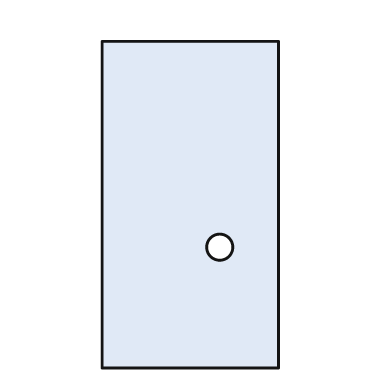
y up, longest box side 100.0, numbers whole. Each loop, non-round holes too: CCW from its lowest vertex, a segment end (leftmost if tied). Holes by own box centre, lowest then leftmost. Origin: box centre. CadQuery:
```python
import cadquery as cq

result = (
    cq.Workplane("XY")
    .moveTo(-27.0, -50.0)
    .lineTo(27.0, -50.0)
    .lineTo(27.0, 50.0)
    .lineTo(-27.0, 50.0)
    .close()
    .moveTo(9.0, -13.0)
    .circle(4.0)
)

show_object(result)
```